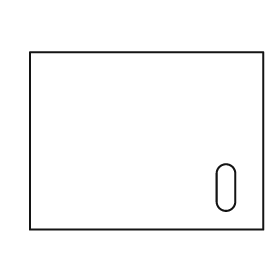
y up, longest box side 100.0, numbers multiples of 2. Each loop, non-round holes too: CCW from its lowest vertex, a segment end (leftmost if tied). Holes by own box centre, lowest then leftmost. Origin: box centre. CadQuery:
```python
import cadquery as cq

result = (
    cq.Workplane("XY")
    .moveTo(-50.0, -38.0)
    .lineTo(50.0, -38.0)
    .lineTo(50.0, 38.0)
    .lineTo(-50.0, 38.0)
    .close()
    .moveTo(30.0, -26.0)
    .threePointArc((34.0, -30.0), (38.0, -26.0))
    .lineTo(38.0, -14.0)
    .threePointArc((34.0, -10.0), (30.0, -14.0))
    .close()
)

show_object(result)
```